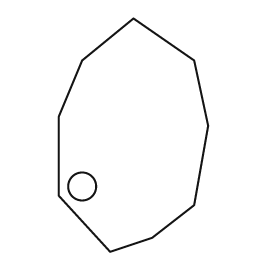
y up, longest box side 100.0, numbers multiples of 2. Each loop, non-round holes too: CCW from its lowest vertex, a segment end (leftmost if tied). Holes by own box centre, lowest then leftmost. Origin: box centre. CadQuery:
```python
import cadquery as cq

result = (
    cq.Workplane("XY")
    .moveTo(-10.0, -50.0)
    .lineTo(8.0, -44.0)
    .lineTo(26.0, -30.0)
    .lineTo(32.0, 4.0)
    .lineTo(26.0, 32.0)
    .lineTo(0.0, 50.0)
    .lineTo(-22.0, 32.0)
    .lineTo(-32.0, 8.0)
    .lineTo(-32.0, -26.0)
    .close()
    .moveTo(-22.0, -22.0)
    .circle(6.0)
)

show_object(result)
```